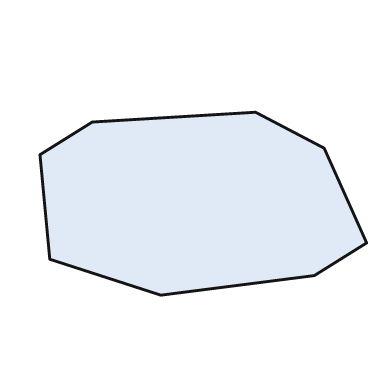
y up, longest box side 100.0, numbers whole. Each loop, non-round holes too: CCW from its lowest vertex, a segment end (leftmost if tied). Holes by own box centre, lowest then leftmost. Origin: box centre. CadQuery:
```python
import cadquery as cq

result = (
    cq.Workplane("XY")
    .moveTo(-13.0, -28.0)
    .lineTo(34.0, -22.0)
    .lineTo(50.0, -12.0)
    .lineTo(37.0, 17.0)
    .lineTo(16.0, 28.0)
    .lineTo(-34.0, 25.0)
    .lineTo(-50.0, 15.0)
    .lineTo(-47.0, -17.0)
    .close()
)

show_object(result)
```